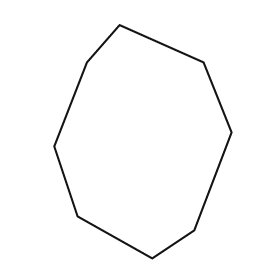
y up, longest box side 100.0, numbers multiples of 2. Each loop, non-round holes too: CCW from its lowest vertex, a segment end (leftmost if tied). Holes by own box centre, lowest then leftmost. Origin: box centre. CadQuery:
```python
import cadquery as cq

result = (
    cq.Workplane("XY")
    .moveTo(4.0, -50.0)
    .lineTo(22.0, -38.0)
    .lineTo(38.0, 4.0)
    .lineTo(26.0, 34.0)
    .lineTo(-10.0, 50.0)
    .lineTo(-24.0, 34.0)
    .lineTo(-38.0, -2.0)
    .lineTo(-28.0, -32.0)
    .close()
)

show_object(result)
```